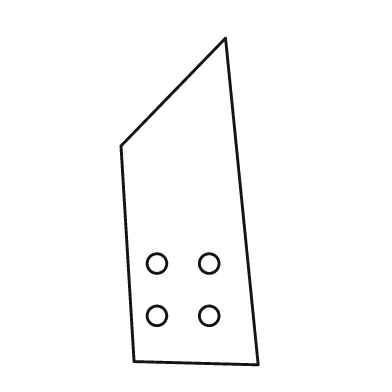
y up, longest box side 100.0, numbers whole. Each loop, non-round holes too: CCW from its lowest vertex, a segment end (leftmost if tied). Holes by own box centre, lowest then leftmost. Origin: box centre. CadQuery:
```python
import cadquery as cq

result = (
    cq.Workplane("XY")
    .moveTo(21.0, -50.0)
    .lineTo(11.0, 50.0)
    .lineTo(-21.0, 17.0)
    .lineTo(-17.0, -49.0)
    .close()
    .moveTo(-10.0, -35.0)
    .circle(3.0)
    .moveTo(6.0, -35.0)
    .circle(3.0)
    .moveTo(-10.0, -19.0)
    .circle(3.0)
    .moveTo(6.0, -19.0)
    .circle(3.0)
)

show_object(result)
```